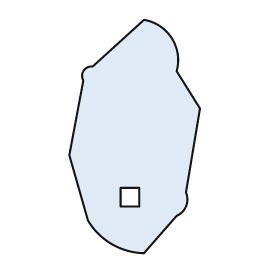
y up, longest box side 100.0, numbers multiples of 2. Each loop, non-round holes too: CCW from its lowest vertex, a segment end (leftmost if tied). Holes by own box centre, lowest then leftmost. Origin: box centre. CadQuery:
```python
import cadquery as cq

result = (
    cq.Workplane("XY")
    .moveTo(4.0, -50.0)
    .lineTo(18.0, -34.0)
    .threePointArc((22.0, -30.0), (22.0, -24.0))
    .lineTo(28.0, 12.0)
    .lineTo(18.0, 28.0)
    .threePointArc((16.0, 42.0), (4.0, 50.0))
    .lineTo(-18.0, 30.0)
    .threePointArc((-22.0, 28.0), (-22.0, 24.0))
    .lineTo(-28.0, -8.0)
    .lineTo(-20.0, -36.0)
    .threePointArc((-10.0, -46.0), (4.0, -50.0))
    .close()
    .moveTo(-6.0, -30.0)
    .lineTo(2.0, -30.0)
    .lineTo(2.0, -22.0)
    .lineTo(-6.0, -22.0)
    .close()
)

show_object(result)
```